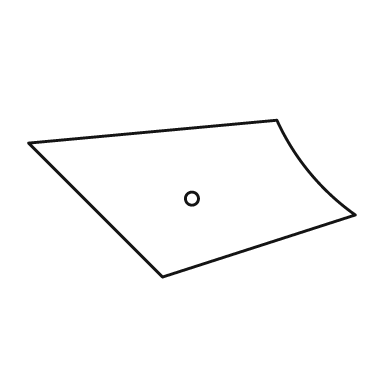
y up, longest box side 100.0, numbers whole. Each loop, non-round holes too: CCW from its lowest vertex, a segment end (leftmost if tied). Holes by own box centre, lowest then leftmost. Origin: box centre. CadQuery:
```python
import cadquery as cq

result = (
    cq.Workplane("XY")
    .moveTo(-9.0, -24.0)
    .lineTo(50.0, -5.0)
    .threePointArc((36.0, 8.0), (26.0, 24.0))
    .lineTo(-50.0, 17.0)
    .close()
    .moveTo(0.0, 0.0)
    .circle(2.0)
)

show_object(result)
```